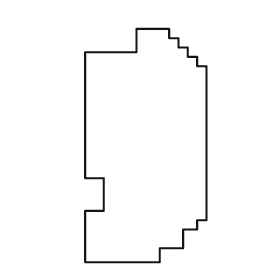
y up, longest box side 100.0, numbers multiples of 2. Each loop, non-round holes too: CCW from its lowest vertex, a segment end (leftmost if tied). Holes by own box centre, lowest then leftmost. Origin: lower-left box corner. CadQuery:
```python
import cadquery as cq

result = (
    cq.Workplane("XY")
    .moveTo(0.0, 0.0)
    .lineTo(32.0, 0.0)
    .lineTo(32.0, 6.0)
    .lineTo(42.0, 6.0)
    .lineTo(42.0, 14.0)
    .lineTo(48.0, 14.0)
    .lineTo(48.0, 18.0)
    .lineTo(52.0, 18.0)
    .lineTo(52.0, 84.0)
    .lineTo(48.0, 84.0)
    .lineTo(48.0, 88.0)
    .lineTo(44.0, 88.0)
    .lineTo(44.0, 92.0)
    .lineTo(40.0, 92.0)
    .lineTo(40.0, 96.0)
    .lineTo(36.0, 96.0)
    .lineTo(36.0, 100.0)
    .lineTo(22.0, 100.0)
    .lineTo(22.0, 90.0)
    .lineTo(0.0, 90.0)
    .lineTo(0.0, 36.0)
    .lineTo(8.0, 36.0)
    .lineTo(8.0, 22.0)
    .lineTo(0.0, 22.0)
    .close()
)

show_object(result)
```